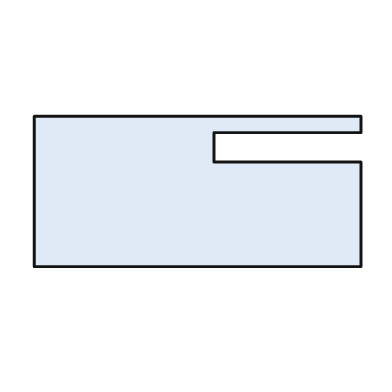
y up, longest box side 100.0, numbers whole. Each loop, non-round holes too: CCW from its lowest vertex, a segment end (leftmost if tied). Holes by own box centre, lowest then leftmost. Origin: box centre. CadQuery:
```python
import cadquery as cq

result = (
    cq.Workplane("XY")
    .moveTo(-50.0, -23.0)
    .lineTo(50.0, -23.0)
    .lineTo(50.0, 9.0)
    .lineTo(5.0, 9.0)
    .lineTo(5.0, 18.0)
    .lineTo(50.0, 18.0)
    .lineTo(50.0, 23.0)
    .lineTo(-50.0, 23.0)
    .close()
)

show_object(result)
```